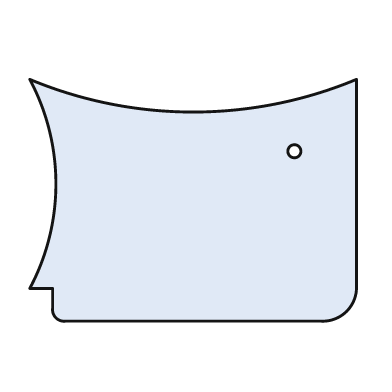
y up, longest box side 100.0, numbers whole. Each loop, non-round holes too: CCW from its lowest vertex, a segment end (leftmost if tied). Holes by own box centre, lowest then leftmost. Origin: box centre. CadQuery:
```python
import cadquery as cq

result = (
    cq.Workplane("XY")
    .moveTo(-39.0, -37.0)
    .lineTo(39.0, -37.0)
    .threePointArc((47.0, -34.0), (50.0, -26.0))
    .lineTo(50.0, 37.0)
    .threePointArc((0.0, 27.0), (-50.0, 37.0))
    .threePointArc((-42.0, 5.0), (-50.0, -27.0))
    .lineTo(-43.0, -27.0)
    .lineTo(-43.0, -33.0)
    .threePointArc((-42.0, -36.0), (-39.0, -37.0))
    .close()
    .moveTo(31.0, 15.0)
    .circle(2.0)
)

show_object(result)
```